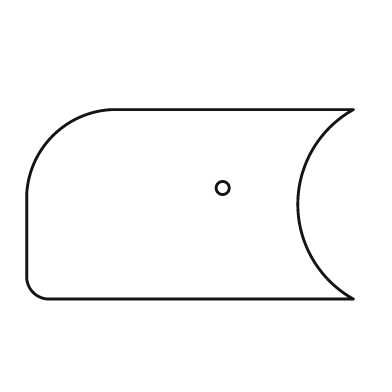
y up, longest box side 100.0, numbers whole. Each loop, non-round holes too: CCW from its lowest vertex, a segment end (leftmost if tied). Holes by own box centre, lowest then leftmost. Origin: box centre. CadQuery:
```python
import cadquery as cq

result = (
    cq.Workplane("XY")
    .moveTo(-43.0, -29.0)
    .lineTo(50.0, -29.0)
    .threePointArc((33.0, 0.0), (50.0, 29.0))
    .lineTo(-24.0, 29.0)
    .threePointArc((-42.0, 21.0), (-50.0, 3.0))
    .lineTo(-50.0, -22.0)
    .threePointArc((-48.0, -27.0), (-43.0, -29.0))
    .close()
    .moveTo(10.0, 5.0)
    .circle(2.0)
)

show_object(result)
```